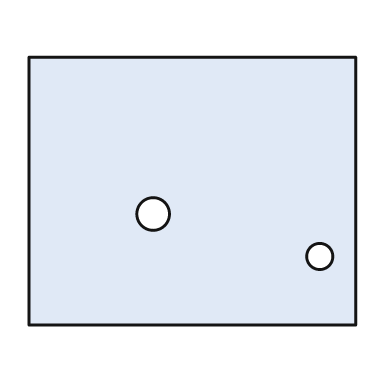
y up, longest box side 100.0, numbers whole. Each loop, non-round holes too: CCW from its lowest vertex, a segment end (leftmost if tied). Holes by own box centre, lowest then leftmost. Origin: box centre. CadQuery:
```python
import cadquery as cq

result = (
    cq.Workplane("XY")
    .moveTo(-50.0, -41.0)
    .lineTo(50.0, -41.0)
    .lineTo(50.0, 41.0)
    .lineTo(-50.0, 41.0)
    .close()
    .moveTo(39.0, -20.0)
    .circle(4.0)
    .moveTo(-12.0, -7.0)
    .circle(5.0)
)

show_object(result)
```